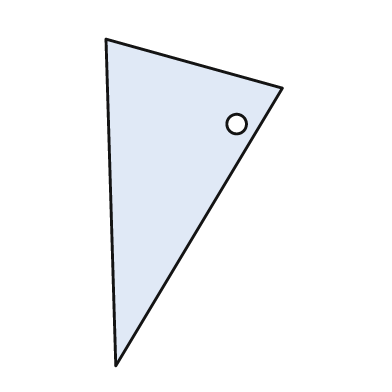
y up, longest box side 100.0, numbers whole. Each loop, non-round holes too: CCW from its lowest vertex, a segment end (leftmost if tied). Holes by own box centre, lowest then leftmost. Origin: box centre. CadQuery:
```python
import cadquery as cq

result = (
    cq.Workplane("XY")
    .moveTo(-24.0, -50.0)
    .lineTo(27.0, 35.0)
    .lineTo(-27.0, 50.0)
    .close()
    .moveTo(13.0, 24.0)
    .circle(3.0)
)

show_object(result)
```